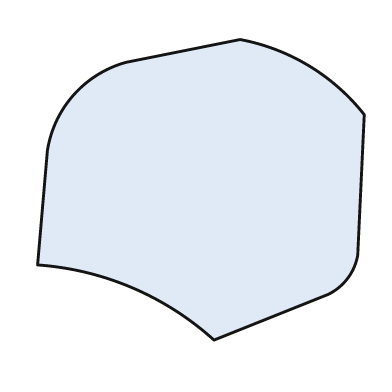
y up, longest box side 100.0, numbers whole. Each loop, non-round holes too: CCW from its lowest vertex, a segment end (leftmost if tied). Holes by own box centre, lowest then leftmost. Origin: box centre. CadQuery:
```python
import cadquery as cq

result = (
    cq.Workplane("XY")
    .moveTo(4.0, -46.0)
    .lineTo(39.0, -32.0)
    .threePointArc((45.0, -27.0), (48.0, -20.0))
    .lineTo(50.0, 23.0)
    .threePointArc((33.0, 38.0), (12.0, 46.0))
    .lineTo(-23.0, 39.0)
    .threePointArc((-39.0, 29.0), (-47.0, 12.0))
    .lineTo(-50.0, -23.0)
    .threePointArc((-21.0, -30.0), (4.0, -46.0))
    .close()
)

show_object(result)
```